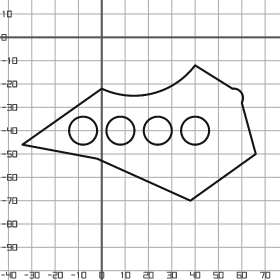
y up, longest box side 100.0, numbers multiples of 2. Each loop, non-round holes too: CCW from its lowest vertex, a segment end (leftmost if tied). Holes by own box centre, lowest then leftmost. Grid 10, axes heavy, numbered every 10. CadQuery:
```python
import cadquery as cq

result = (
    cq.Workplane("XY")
    .moveTo(38.0, -70.0)
    .lineTo(66.0, -50.0)
    .lineTo(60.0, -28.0)
    .threePointArc((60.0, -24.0), (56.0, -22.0))
    .lineTo(40.0, -12.0)
    .threePointArc((22.0, -24.0), (0.0, -22.0))
    .lineTo(-34.0, -46.0)
    .lineTo(-2.0, -52.0)
    .close()
    .moveTo(-8.0, -40.0)
    .circle(6.0)
    .moveTo(8.0, -40.0)
    .circle(6.0)
    .moveTo(24.0, -40.0)
    .circle(6.0)
    .moveTo(40.0, -40.0)
    .circle(6.0)
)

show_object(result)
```